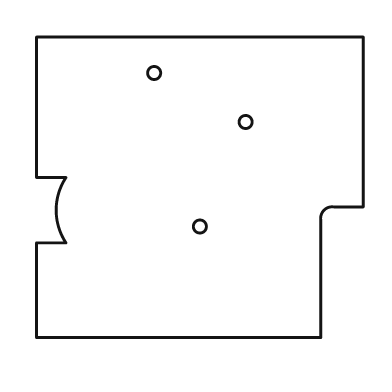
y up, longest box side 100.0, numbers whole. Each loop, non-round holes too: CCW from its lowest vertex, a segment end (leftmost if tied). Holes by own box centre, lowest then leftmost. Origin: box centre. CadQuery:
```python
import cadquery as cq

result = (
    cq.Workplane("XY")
    .moveTo(-50.0, -46.0)
    .lineTo(37.0, -46.0)
    .lineTo(37.0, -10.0)
    .threePointArc((38.0, -7.0), (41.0, -6.0))
    .lineTo(50.0, -6.0)
    .lineTo(50.0, 46.0)
    .lineTo(-50.0, 46.0)
    .lineTo(-50.0, 3.0)
    .lineTo(-41.0, 3.0)
    .threePointArc((-44.0, -7.0), (-41.0, -17.0))
    .lineTo(-50.0, -17.0)
    .close()
    .moveTo(0.0, -12.0)
    .circle(2.0)
    .moveTo(14.0, 20.0)
    .circle(2.0)
    .moveTo(-14.0, 35.0)
    .circle(2.0)
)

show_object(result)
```